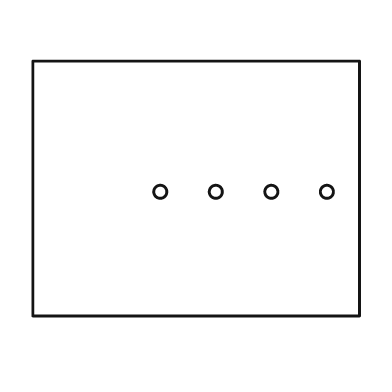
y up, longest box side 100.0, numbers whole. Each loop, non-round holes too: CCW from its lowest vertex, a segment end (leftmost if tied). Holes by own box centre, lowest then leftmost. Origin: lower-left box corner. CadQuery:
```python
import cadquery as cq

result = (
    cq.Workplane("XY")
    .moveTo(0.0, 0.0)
    .lineTo(100.0, 0.0)
    .lineTo(100.0, 78.0)
    .lineTo(0.0, 78.0)
    .close()
    .moveTo(39.0, 38.0)
    .circle(2.0)
    .moveTo(56.0, 38.0)
    .circle(2.0)
    .moveTo(73.0, 38.0)
    .circle(2.0)
    .moveTo(90.0, 38.0)
    .circle(2.0)
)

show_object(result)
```